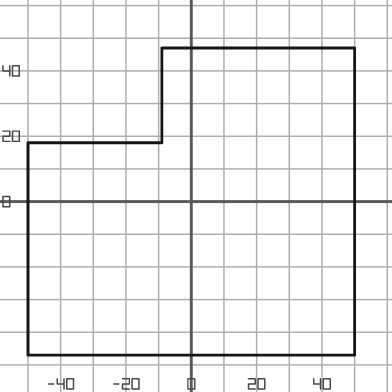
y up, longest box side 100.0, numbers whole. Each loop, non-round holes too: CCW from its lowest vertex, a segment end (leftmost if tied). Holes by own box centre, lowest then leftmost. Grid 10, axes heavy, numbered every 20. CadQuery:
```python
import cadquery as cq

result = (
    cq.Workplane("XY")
    .moveTo(-50.0, -47.0)
    .lineTo(50.0, -47.0)
    .lineTo(50.0, 47.0)
    .lineTo(-9.0, 47.0)
    .lineTo(-9.0, 18.0)
    .lineTo(-50.0, 18.0)
    .close()
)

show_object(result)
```